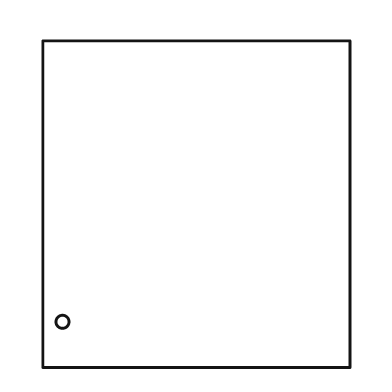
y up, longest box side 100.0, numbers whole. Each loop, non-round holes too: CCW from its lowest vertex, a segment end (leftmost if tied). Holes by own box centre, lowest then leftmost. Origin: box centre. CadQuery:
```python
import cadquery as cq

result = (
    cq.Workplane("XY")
    .moveTo(-47.0, -50.0)
    .lineTo(47.0, -50.0)
    .lineTo(47.0, 50.0)
    .lineTo(-47.0, 50.0)
    .close()
    .moveTo(-41.0, -36.0)
    .circle(2.0)
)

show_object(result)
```